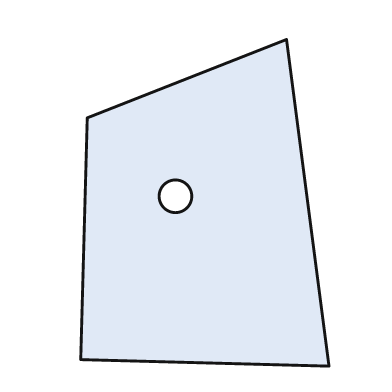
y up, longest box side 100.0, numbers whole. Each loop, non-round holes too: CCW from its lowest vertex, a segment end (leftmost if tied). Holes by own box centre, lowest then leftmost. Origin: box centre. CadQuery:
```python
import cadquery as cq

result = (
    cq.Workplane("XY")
    .moveTo(38.0, -50.0)
    .lineTo(25.0, 50.0)
    .lineTo(-36.0, 26.0)
    .lineTo(-38.0, -48.0)
    .close()
    .moveTo(-9.0, 2.0)
    .circle(5.0)
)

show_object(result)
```